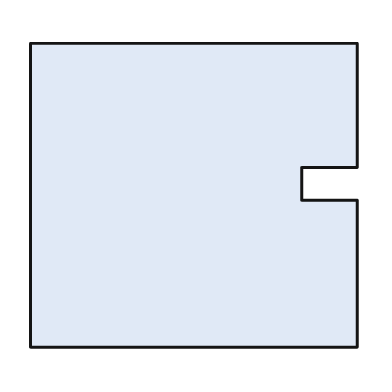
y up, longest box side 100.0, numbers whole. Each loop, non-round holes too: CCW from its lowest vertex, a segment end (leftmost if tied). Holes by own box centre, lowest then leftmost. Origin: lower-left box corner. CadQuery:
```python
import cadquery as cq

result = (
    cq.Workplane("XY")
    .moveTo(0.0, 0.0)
    .lineTo(100.0, 0.0)
    .lineTo(100.0, 45.0)
    .lineTo(83.0, 45.0)
    .lineTo(83.0, 55.0)
    .lineTo(100.0, 55.0)
    .lineTo(100.0, 93.0)
    .lineTo(0.0, 93.0)
    .close()
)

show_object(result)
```